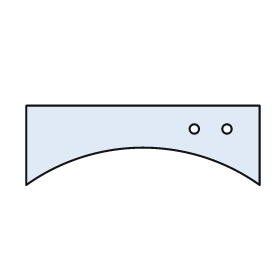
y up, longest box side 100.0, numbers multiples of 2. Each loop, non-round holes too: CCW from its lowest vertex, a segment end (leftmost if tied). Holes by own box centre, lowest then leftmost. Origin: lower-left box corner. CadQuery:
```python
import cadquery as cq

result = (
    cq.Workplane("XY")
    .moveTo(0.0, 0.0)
    .threePointArc((50.0, 16.0), (100.0, 0.0))
    .lineTo(100.0, 34.0)
    .lineTo(0.0, 34.0)
    .close()
    .moveTo(72.0, 24.0)
    .circle(2.0)
    .moveTo(86.0, 24.0)
    .circle(2.0)
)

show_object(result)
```